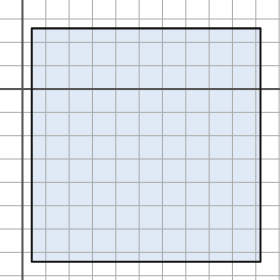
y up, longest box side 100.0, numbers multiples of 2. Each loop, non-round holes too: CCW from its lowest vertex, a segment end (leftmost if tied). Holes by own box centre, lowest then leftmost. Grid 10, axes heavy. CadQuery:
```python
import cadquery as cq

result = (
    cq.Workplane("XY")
    .moveTo(4.0, -74.0)
    .lineTo(102.0, -74.0)
    .lineTo(102.0, 26.0)
    .lineTo(4.0, 26.0)
    .close()
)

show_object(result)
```